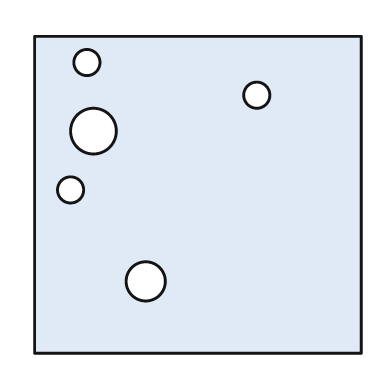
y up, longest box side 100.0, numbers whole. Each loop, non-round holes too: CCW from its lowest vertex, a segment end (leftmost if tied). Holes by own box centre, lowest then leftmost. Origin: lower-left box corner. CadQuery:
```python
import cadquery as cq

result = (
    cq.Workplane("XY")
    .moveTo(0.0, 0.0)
    .lineTo(100.0, 0.0)
    .lineTo(100.0, 97.0)
    .lineTo(0.0, 97.0)
    .close()
    .moveTo(34.0, 22.0)
    .circle(6.0)
    .moveTo(11.0, 50.0)
    .circle(4.0)
    .moveTo(18.0, 68.0)
    .circle(7.0)
    .moveTo(68.0, 79.0)
    .circle(4.0)
    .moveTo(16.0, 89.0)
    .circle(4.0)
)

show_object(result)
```